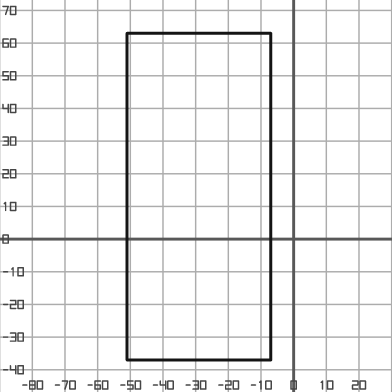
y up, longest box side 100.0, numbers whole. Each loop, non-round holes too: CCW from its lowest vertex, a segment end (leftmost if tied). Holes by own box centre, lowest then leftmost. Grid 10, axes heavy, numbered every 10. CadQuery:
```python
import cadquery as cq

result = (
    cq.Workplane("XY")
    .moveTo(-51.0, -37.0)
    .lineTo(-7.0, -37.0)
    .lineTo(-7.0, 63.0)
    .lineTo(-51.0, 63.0)
    .close()
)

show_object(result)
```